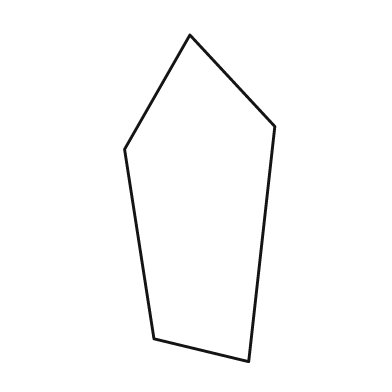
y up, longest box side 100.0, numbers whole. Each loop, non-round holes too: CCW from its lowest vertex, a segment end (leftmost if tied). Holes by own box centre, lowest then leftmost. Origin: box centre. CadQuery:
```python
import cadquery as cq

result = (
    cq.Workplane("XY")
    .moveTo(15.0, -50.0)
    .lineTo(23.0, 22.0)
    .lineTo(-3.0, 50.0)
    .lineTo(-23.0, 15.0)
    .lineTo(-14.0, -43.0)
    .close()
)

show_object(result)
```